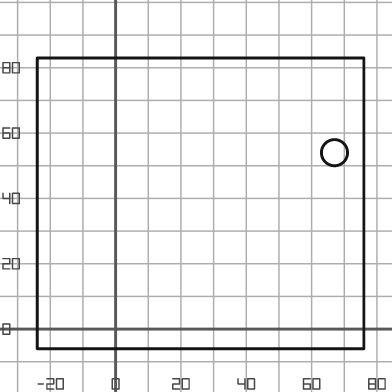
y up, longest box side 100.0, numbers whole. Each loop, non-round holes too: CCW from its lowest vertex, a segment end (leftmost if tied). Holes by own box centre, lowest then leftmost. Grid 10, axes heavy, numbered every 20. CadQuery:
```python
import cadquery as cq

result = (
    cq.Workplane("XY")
    .moveTo(-24.0, -6.0)
    .lineTo(76.0, -6.0)
    .lineTo(76.0, 83.0)
    .lineTo(-24.0, 83.0)
    .close()
    .moveTo(67.0, 54.0)
    .circle(4.0)
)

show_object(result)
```